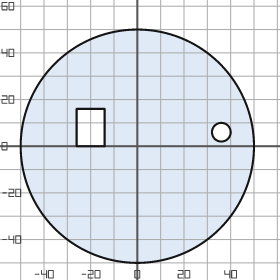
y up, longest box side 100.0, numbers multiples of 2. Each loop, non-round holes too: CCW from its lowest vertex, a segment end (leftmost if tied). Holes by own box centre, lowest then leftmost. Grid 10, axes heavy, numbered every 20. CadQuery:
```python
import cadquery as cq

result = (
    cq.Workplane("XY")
    .moveTo(0.0, 0.0)
    .circle(50.0)
    .moveTo(36.0, 6.0)
    .circle(4.0)
    .moveTo(-26.0, 0.0)
    .lineTo(-14.0, 0.0)
    .lineTo(-14.0, 16.0)
    .lineTo(-26.0, 16.0)
    .close()
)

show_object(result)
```